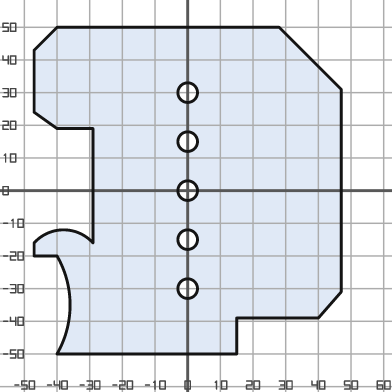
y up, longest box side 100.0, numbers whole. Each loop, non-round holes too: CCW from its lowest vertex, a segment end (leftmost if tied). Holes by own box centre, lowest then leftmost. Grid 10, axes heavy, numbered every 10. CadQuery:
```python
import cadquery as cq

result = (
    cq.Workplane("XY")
    .moveTo(-40.0, -50.0)
    .lineTo(15.0, -50.0)
    .lineTo(15.0, -39.0)
    .lineTo(40.0, -39.0)
    .lineTo(47.0, -31.0)
    .lineTo(47.0, 31.0)
    .lineTo(28.0, 50.0)
    .lineTo(-40.0, 50.0)
    .lineTo(-47.0, 43.0)
    .lineTo(-47.0, 24.0)
    .lineTo(-40.0, 19.0)
    .lineTo(-29.0, 19.0)
    .lineTo(-29.0, -16.0)
    .threePointArc((-38.0, -12.0), (-47.0, -16.0))
    .lineTo(-47.0, -20.0)
    .lineTo(-40.0, -20.0)
    .threePointArc((-36.0, -35.0), (-40.0, -50.0))
    .close()
    .moveTo(0.0, -30.0)
    .circle(3.0)
    .moveTo(0.0, -15.0)
    .circle(3.0)
    .moveTo(0.0, 0.0)
    .circle(3.0)
    .moveTo(0.0, 15.0)
    .circle(3.0)
    .moveTo(0.0, 30.0)
    .circle(3.0)
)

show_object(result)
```